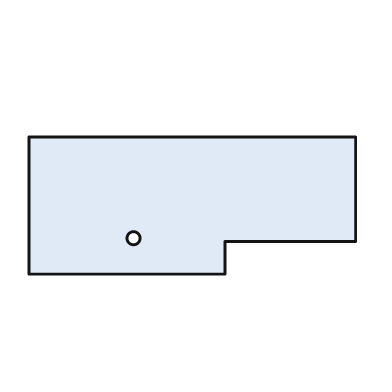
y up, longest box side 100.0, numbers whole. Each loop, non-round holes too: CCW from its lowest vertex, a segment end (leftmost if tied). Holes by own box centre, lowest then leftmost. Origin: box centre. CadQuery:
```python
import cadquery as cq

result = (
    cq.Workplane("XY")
    .moveTo(-50.0, -21.0)
    .lineTo(10.0, -21.0)
    .lineTo(10.0, -11.0)
    .lineTo(50.0, -11.0)
    .lineTo(50.0, 21.0)
    .lineTo(-50.0, 21.0)
    .close()
    .moveTo(-18.0, -10.0)
    .circle(2.0)
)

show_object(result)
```